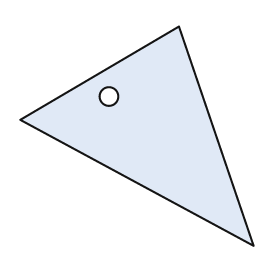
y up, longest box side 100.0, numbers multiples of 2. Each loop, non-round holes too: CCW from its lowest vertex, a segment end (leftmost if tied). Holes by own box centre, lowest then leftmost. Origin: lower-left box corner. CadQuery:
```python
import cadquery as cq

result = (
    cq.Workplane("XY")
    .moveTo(100.0, 0.0)
    .lineTo(68.0, 94.0)
    .lineTo(0.0, 54.0)
    .close()
    .moveTo(38.0, 64.0)
    .circle(4.0)
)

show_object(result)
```